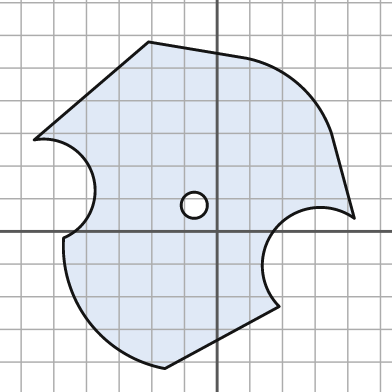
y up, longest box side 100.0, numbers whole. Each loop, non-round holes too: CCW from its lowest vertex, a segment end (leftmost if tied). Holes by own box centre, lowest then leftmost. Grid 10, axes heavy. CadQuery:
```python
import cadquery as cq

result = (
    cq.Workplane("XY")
    .moveTo(-16.0, -42.0)
    .lineTo(19.0, -23.0)
    .threePointArc((18.0, 1.0), (42.0, 4.0))
    .lineTo(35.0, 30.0)
    .threePointArc((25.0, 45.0), (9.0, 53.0))
    .lineTo(-21.0, 58.0)
    .lineTo(-56.0, 28.0)
    .threePointArc((-38.0, 17.0), (-47.0, -2.0))
    .threePointArc((-39.0, -28.0), (-16.0, -42.0))
    .close()
    .moveTo(-7.0, 8.0)
    .circle(4.0)
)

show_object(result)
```